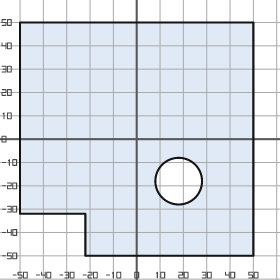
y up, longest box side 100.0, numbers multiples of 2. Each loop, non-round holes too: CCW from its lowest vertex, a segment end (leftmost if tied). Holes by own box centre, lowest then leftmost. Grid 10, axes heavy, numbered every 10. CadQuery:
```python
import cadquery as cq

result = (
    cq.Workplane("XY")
    .moveTo(-22.0, -50.0)
    .lineTo(50.0, -50.0)
    .lineTo(50.0, 50.0)
    .lineTo(-50.0, 50.0)
    .lineTo(-50.0, -32.0)
    .lineTo(-22.0, -32.0)
    .close()
    .moveTo(18.0, -18.0)
    .circle(10.0)
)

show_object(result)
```